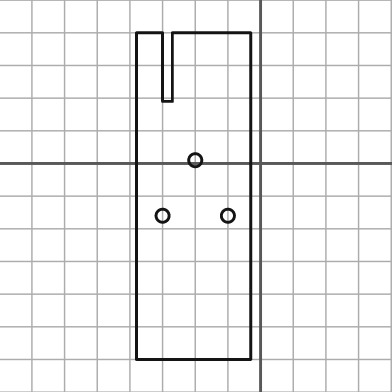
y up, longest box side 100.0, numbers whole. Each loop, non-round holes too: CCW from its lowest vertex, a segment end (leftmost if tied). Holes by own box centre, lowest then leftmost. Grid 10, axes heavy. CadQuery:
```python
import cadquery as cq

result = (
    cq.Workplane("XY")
    .moveTo(-38.0, -60.0)
    .lineTo(-3.0, -60.0)
    .lineTo(-3.0, 40.0)
    .lineTo(-27.0, 40.0)
    .lineTo(-27.0, 19.0)
    .lineTo(-30.0, 19.0)
    .lineTo(-30.0, 40.0)
    .lineTo(-38.0, 40.0)
    .close()
    .moveTo(-30.0, -16.0)
    .circle(2.0)
    .moveTo(-10.0, -16.0)
    .circle(2.0)
    .moveTo(-20.0, 1.0)
    .circle(2.0)
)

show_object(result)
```